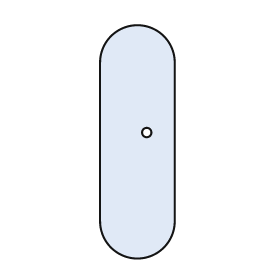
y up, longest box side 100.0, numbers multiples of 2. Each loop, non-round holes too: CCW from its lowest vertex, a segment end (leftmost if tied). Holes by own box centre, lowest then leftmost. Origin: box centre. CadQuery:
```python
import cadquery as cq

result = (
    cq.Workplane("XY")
    .moveTo(-16.0, -34.0)
    .threePointArc((0.0, -50.0), (16.0, -34.0))
    .lineTo(16.0, 34.0)
    .threePointArc((0.0, 50.0), (-16.0, 34.0))
    .close()
    .moveTo(4.0, 4.0)
    .circle(2.0)
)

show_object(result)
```